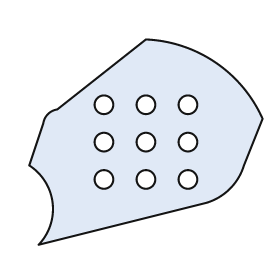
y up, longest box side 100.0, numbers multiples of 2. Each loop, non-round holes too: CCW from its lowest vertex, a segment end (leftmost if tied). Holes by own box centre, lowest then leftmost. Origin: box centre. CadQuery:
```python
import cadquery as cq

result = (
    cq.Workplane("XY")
    .moveTo(-46.0, -44.0)
    .lineTo(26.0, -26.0)
    .threePointArc((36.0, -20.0), (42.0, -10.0))
    .lineTo(50.0, 10.0)
    .threePointArc((30.0, 34.0), (0.0, 44.0))
    .lineTo(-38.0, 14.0)
    .threePointArc((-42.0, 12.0), (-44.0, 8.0))
    .lineTo(-50.0, -10.0)
    .threePointArc((-40.0, -26.0), (-46.0, -44.0))
    .close()
    .moveTo(-18.0, -16.0)
    .circle(4.0)
    .moveTo(0.0, -16.0)
    .circle(4.0)
    .moveTo(18.0, -16.0)
    .circle(4.0)
    .moveTo(-18.0, 0.0)
    .circle(4.0)
    .moveTo(0.0, 0.0)
    .circle(4.0)
    .moveTo(18.0, 0.0)
    .circle(4.0)
    .moveTo(-18.0, 16.0)
    .circle(4.0)
    .moveTo(0.0, 16.0)
    .circle(4.0)
    .moveTo(18.0, 16.0)
    .circle(4.0)
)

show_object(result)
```